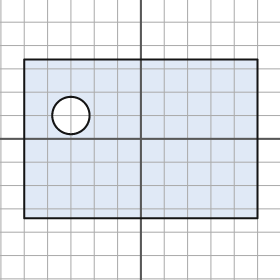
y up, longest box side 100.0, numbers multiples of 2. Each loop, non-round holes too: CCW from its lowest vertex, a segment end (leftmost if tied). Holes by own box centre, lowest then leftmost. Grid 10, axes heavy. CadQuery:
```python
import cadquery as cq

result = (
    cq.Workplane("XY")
    .moveTo(-50.0, -34.0)
    .lineTo(50.0, -34.0)
    .lineTo(50.0, 34.0)
    .lineTo(-50.0, 34.0)
    .close()
    .moveTo(-30.0, 10.0)
    .circle(8.0)
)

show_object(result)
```